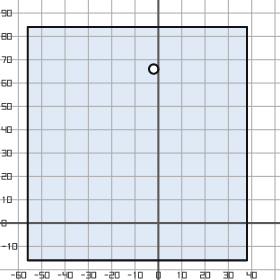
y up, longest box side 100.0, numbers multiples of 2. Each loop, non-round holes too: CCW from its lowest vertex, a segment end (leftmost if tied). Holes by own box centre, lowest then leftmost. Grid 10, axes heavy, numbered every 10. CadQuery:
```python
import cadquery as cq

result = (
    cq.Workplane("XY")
    .moveTo(-56.0, -16.0)
    .lineTo(38.0, -16.0)
    .lineTo(38.0, 84.0)
    .lineTo(-56.0, 84.0)
    .close()
    .moveTo(-2.0, 66.0)
    .circle(2.0)
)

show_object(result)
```